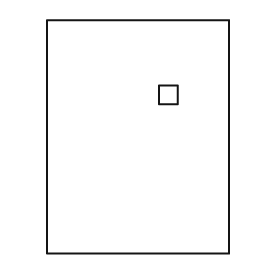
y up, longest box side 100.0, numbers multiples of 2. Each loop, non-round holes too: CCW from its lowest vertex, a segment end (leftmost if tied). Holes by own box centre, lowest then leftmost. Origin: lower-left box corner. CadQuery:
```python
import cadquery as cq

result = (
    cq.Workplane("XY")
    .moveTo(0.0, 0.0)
    .lineTo(78.0, 0.0)
    .lineTo(78.0, 100.0)
    .lineTo(0.0, 100.0)
    .close()
    .moveTo(48.0, 64.0)
    .lineTo(56.0, 64.0)
    .lineTo(56.0, 72.0)
    .lineTo(48.0, 72.0)
    .close()
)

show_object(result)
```